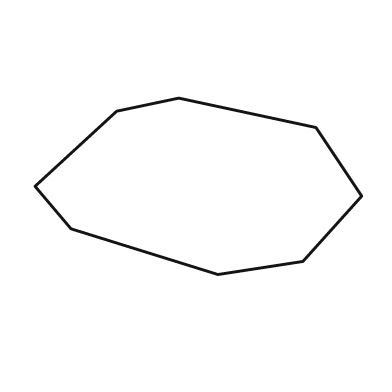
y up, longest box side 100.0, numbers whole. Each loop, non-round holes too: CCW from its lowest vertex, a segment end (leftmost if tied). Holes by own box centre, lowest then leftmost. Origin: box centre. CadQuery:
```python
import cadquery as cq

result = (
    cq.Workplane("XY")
    .moveTo(6.0, -27.0)
    .lineTo(32.0, -23.0)
    .lineTo(50.0, -3.0)
    .lineTo(36.0, 18.0)
    .lineTo(-6.0, 27.0)
    .lineTo(-25.0, 23.0)
    .lineTo(-50.0, 0.0)
    .lineTo(-39.0, -13.0)
    .close()
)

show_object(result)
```